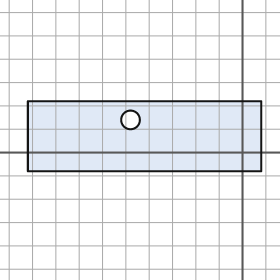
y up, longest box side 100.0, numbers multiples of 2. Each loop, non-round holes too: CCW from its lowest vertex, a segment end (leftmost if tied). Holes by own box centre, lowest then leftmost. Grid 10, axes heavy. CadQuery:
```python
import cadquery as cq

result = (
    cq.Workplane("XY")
    .moveTo(-92.0, -8.0)
    .lineTo(8.0, -8.0)
    .lineTo(8.0, 22.0)
    .lineTo(-92.0, 22.0)
    .close()
    .moveTo(-48.0, 14.0)
    .circle(4.0)
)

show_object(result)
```